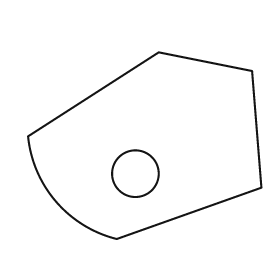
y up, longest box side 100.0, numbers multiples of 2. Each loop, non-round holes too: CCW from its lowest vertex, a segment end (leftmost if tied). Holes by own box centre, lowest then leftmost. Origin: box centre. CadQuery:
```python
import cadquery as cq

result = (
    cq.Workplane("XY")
    .moveTo(-12.0, -40.0)
    .lineTo(50.0, -18.0)
    .lineTo(46.0, 32.0)
    .lineTo(6.0, 40.0)
    .lineTo(-50.0, 4.0)
    .threePointArc((-38.0, -24.0), (-12.0, -40.0))
    .close()
    .moveTo(-4.0, -12.0)
    .circle(10.0)
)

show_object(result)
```